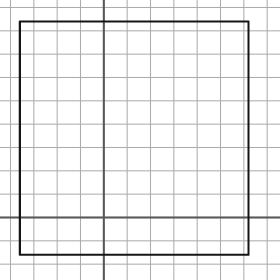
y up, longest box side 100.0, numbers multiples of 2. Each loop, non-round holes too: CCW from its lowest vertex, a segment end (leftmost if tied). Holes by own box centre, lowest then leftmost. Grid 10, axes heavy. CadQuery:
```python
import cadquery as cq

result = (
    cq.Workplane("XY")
    .moveTo(-36.0, -16.0)
    .lineTo(62.0, -16.0)
    .lineTo(62.0, 84.0)
    .lineTo(-36.0, 84.0)
    .close()
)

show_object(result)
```